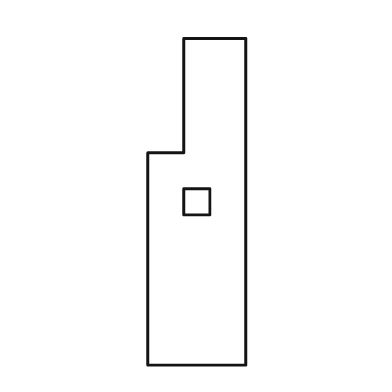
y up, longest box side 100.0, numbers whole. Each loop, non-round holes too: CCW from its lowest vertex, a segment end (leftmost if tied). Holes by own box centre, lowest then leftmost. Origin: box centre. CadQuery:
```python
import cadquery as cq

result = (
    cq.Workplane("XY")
    .moveTo(-15.0, -50.0)
    .lineTo(15.0, -50.0)
    .lineTo(15.0, 50.0)
    .lineTo(-4.0, 50.0)
    .lineTo(-4.0, 15.0)
    .lineTo(-15.0, 15.0)
    .close()
    .moveTo(-4.0, -4.0)
    .lineTo(4.0, -4.0)
    .lineTo(4.0, 4.0)
    .lineTo(-4.0, 4.0)
    .close()
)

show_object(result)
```